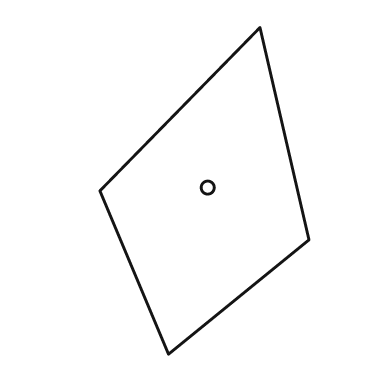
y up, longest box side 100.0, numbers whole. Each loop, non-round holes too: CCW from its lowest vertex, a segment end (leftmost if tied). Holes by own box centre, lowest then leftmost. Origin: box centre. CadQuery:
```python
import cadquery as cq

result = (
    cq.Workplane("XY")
    .moveTo(-11.0, -50.0)
    .lineTo(32.0, -15.0)
    .lineTo(17.0, 50.0)
    .lineTo(-32.0, 0.0)
    .close()
    .moveTo(1.0, 1.0)
    .circle(2.0)
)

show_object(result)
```